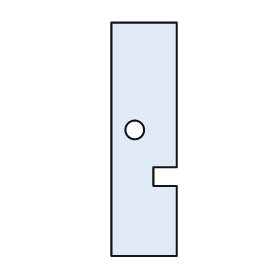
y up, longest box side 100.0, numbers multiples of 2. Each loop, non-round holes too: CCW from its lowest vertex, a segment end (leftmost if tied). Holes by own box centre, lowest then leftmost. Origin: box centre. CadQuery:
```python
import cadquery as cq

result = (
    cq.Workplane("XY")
    .moveTo(-14.0, -50.0)
    .lineTo(14.0, -50.0)
    .lineTo(14.0, -20.0)
    .lineTo(4.0, -20.0)
    .lineTo(4.0, -12.0)
    .lineTo(14.0, -12.0)
    .lineTo(14.0, 50.0)
    .lineTo(-14.0, 50.0)
    .close()
    .moveTo(-4.0, 4.0)
    .circle(4.0)
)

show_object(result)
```